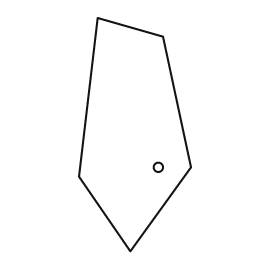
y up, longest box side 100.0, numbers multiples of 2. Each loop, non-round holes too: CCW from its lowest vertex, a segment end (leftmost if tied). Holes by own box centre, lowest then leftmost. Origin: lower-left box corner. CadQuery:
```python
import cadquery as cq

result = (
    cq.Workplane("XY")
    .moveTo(22.0, 0.0)
    .lineTo(48.0, 36.0)
    .lineTo(36.0, 92.0)
    .lineTo(8.0, 100.0)
    .lineTo(0.0, 32.0)
    .close()
    .moveTo(34.0, 36.0)
    .circle(2.0)
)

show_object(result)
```